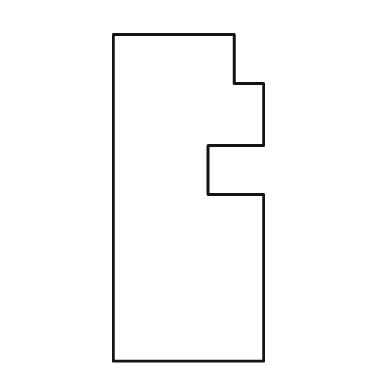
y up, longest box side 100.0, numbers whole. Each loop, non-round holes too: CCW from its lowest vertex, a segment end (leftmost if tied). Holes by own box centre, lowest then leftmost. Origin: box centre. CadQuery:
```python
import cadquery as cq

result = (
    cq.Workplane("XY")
    .moveTo(-23.0, -50.0)
    .lineTo(23.0, -50.0)
    .lineTo(23.0, 1.0)
    .lineTo(6.0, 1.0)
    .lineTo(6.0, 16.0)
    .lineTo(23.0, 16.0)
    .lineTo(23.0, 35.0)
    .lineTo(14.0, 35.0)
    .lineTo(14.0, 50.0)
    .lineTo(-23.0, 50.0)
    .close()
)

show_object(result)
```